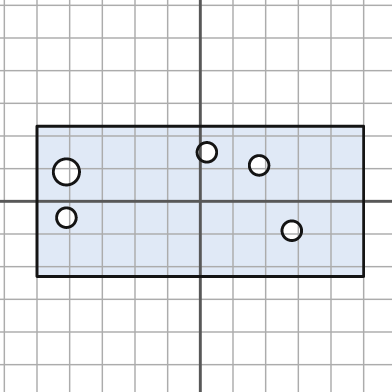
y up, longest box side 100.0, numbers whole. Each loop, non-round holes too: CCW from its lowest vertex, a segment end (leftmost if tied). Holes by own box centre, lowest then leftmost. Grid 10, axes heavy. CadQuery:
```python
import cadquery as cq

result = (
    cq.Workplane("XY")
    .moveTo(-50.0, -23.0)
    .lineTo(50.0, -23.0)
    .lineTo(50.0, 23.0)
    .lineTo(-50.0, 23.0)
    .close()
    .moveTo(28.0, -9.0)
    .circle(3.0)
    .moveTo(-41.0, -5.0)
    .circle(3.0)
    .moveTo(-41.0, 9.0)
    .circle(4.0)
    .moveTo(18.0, 11.0)
    .circle(3.0)
    .moveTo(2.0, 15.0)
    .circle(3.0)
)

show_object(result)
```